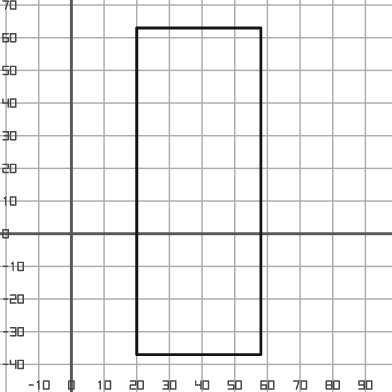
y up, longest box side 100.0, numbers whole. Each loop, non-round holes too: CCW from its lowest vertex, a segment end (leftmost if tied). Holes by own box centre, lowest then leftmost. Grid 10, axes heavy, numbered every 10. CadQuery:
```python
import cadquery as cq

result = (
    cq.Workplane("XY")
    .moveTo(20.0, -37.0)
    .lineTo(58.0, -37.0)
    .lineTo(58.0, 63.0)
    .lineTo(20.0, 63.0)
    .close()
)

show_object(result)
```